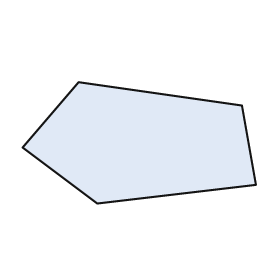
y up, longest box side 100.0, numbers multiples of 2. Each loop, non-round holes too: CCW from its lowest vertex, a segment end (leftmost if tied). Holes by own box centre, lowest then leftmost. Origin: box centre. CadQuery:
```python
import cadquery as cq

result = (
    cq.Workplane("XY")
    .moveTo(-18.0, -26.0)
    .lineTo(50.0, -18.0)
    .lineTo(44.0, 16.0)
    .lineTo(-26.0, 26.0)
    .lineTo(-50.0, -2.0)
    .close()
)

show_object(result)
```